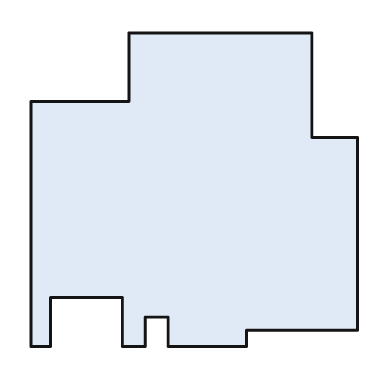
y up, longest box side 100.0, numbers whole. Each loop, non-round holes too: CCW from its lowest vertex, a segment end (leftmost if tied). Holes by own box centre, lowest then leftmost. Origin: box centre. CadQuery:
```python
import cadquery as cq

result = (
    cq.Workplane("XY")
    .moveTo(-50.0, -48.0)
    .lineTo(-44.0, -48.0)
    .lineTo(-44.0, -33.0)
    .lineTo(-22.0, -33.0)
    .lineTo(-22.0, -48.0)
    .lineTo(-15.0, -48.0)
    .lineTo(-15.0, -39.0)
    .lineTo(-8.0, -39.0)
    .lineTo(-8.0, -48.0)
    .lineTo(16.0, -48.0)
    .lineTo(16.0, -43.0)
    .lineTo(50.0, -43.0)
    .lineTo(50.0, 16.0)
    .lineTo(36.0, 16.0)
    .lineTo(36.0, 48.0)
    .lineTo(-20.0, 48.0)
    .lineTo(-20.0, 27.0)
    .lineTo(-50.0, 27.0)
    .close()
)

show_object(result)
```